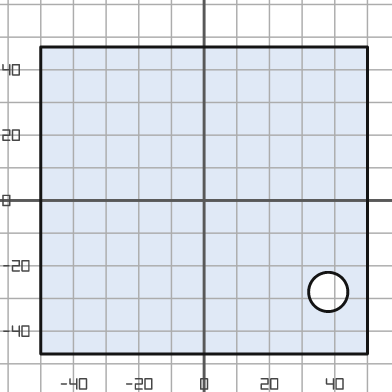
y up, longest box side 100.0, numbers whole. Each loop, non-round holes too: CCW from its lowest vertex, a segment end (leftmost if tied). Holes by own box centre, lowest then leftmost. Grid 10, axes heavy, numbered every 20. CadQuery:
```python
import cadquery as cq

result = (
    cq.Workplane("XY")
    .moveTo(-50.0, -47.0)
    .lineTo(50.0, -47.0)
    .lineTo(50.0, 47.0)
    .lineTo(-50.0, 47.0)
    .close()
    .moveTo(38.0, -28.0)
    .circle(6.0)
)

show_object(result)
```